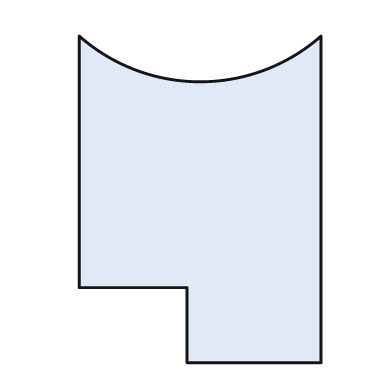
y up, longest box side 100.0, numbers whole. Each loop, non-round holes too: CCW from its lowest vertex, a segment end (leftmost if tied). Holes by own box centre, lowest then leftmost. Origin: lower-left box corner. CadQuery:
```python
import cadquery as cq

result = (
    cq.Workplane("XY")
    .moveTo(33.0, 0.0)
    .lineTo(74.0, 0.0)
    .lineTo(74.0, 100.0)
    .threePointArc((37.0, 86.0), (0.0, 100.0))
    .lineTo(0.0, 23.0)
    .lineTo(33.0, 23.0)
    .close()
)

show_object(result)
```